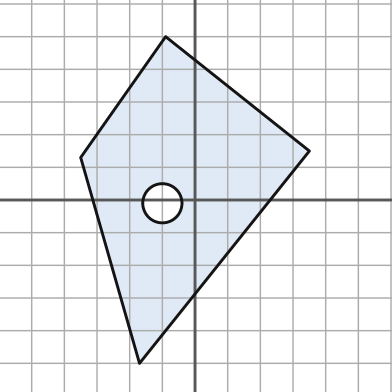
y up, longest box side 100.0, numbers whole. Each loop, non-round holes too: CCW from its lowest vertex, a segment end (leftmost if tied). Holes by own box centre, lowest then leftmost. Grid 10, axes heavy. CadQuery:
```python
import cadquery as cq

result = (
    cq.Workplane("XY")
    .moveTo(-17.0, -50.0)
    .lineTo(35.0, 15.0)
    .lineTo(-9.0, 50.0)
    .lineTo(-35.0, 13.0)
    .close()
    .moveTo(-10.0, -1.0)
    .circle(6.0)
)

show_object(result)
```